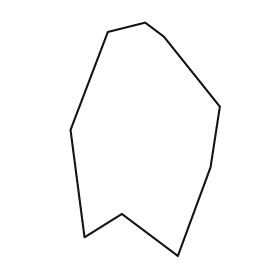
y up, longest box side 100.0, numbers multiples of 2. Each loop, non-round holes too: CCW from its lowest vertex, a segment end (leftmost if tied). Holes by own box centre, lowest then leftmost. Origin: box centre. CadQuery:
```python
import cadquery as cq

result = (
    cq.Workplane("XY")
    .moveTo(14.0, -50.0)
    .lineTo(28.0, -12.0)
    .lineTo(32.0, 14.0)
    .lineTo(8.0, 44.0)
    .lineTo(0.0, 50.0)
    .lineTo(-16.0, 46.0)
    .lineTo(-32.0, 4.0)
    .lineTo(-26.0, -42.0)
    .lineTo(-10.0, -32.0)
    .close()
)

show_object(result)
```